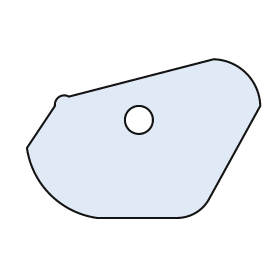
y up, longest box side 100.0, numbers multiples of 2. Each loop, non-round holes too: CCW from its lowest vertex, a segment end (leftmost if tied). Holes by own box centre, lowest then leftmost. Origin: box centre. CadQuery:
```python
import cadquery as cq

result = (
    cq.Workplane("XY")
    .moveTo(-20.0, -34.0)
    .lineTo(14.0, -34.0)
    .threePointArc((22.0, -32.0), (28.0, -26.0))
    .lineTo(50.0, 14.0)
    .threePointArc((44.0, 28.0), (30.0, 34.0))
    .lineTo(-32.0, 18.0)
    .threePointArc((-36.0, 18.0), (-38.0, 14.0))
    .lineTo(-50.0, -4.0)
    .threePointArc((-40.0, -24.0), (-20.0, -34.0))
    .close()
    .moveTo(-2.0, 8.0)
    .circle(6.0)
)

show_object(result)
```